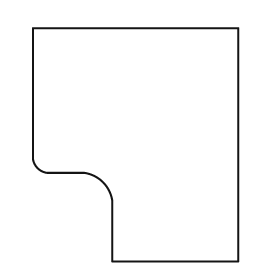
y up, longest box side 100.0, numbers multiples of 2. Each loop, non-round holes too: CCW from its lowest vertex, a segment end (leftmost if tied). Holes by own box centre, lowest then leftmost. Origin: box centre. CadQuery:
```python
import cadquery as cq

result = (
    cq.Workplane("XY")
    .moveTo(-10.0, -50.0)
    .lineTo(44.0, -50.0)
    .lineTo(44.0, 50.0)
    .lineTo(-44.0, 50.0)
    .lineTo(-44.0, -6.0)
    .threePointArc((-42.0, -10.0), (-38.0, -12.0))
    .lineTo(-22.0, -12.0)
    .threePointArc((-14.0, -16.0), (-10.0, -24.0))
    .close()
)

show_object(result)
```